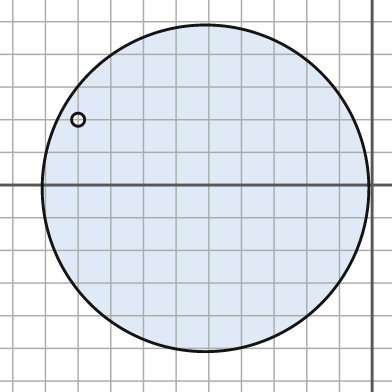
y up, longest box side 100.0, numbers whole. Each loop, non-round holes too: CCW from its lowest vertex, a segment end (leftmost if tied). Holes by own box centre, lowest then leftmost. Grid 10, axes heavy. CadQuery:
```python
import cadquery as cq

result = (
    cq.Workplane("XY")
    .moveTo(-51.0, -1.0)
    .circle(50.0)
    .moveTo(-90.0, 20.0)
    .circle(2.0)
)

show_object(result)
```